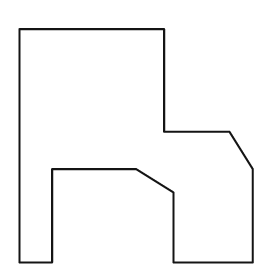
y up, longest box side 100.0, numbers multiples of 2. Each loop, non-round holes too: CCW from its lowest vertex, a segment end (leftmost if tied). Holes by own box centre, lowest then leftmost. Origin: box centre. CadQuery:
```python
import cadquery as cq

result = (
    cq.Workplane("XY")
    .moveTo(-50.0, -50.0)
    .lineTo(-36.0, -50.0)
    .lineTo(-36.0, -10.0)
    .lineTo(0.0, -10.0)
    .lineTo(16.0, -20.0)
    .lineTo(16.0, -50.0)
    .lineTo(50.0, -50.0)
    .lineTo(50.0, -10.0)
    .lineTo(40.0, 6.0)
    .lineTo(12.0, 6.0)
    .lineTo(12.0, 50.0)
    .lineTo(-50.0, 50.0)
    .close()
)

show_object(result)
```